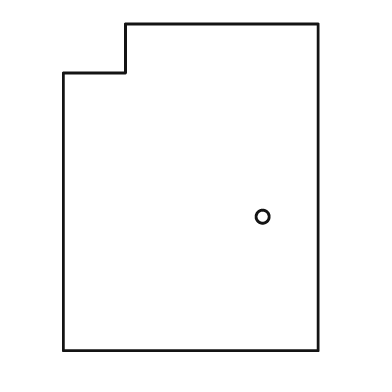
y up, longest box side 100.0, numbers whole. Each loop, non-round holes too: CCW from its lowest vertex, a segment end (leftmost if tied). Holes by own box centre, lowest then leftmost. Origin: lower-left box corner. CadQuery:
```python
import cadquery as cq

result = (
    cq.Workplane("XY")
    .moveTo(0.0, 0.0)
    .lineTo(78.0, 0.0)
    .lineTo(78.0, 100.0)
    .lineTo(19.0, 100.0)
    .lineTo(19.0, 85.0)
    .lineTo(0.0, 85.0)
    .close()
    .moveTo(61.0, 41.0)
    .circle(2.0)
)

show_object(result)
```